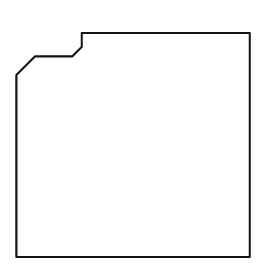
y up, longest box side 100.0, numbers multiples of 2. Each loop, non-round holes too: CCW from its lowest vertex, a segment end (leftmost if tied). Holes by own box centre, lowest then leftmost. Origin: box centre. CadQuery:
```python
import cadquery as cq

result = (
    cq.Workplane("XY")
    .moveTo(-50.0, -48.0)
    .lineTo(50.0, -48.0)
    .lineTo(50.0, 48.0)
    .lineTo(-22.0, 48.0)
    .lineTo(-22.0, 42.0)
    .lineTo(-26.0, 38.0)
    .lineTo(-42.0, 38.0)
    .lineTo(-50.0, 30.0)
    .close()
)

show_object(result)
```